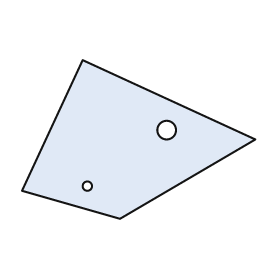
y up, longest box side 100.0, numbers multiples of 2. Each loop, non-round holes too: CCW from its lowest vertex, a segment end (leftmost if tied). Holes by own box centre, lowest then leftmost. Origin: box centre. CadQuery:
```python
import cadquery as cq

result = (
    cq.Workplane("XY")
    .moveTo(-8.0, -34.0)
    .lineTo(50.0, 0.0)
    .lineTo(-24.0, 34.0)
    .lineTo(-50.0, -22.0)
    .close()
    .moveTo(-22.0, -20.0)
    .circle(2.0)
    .moveTo(12.0, 4.0)
    .circle(4.0)
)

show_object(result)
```